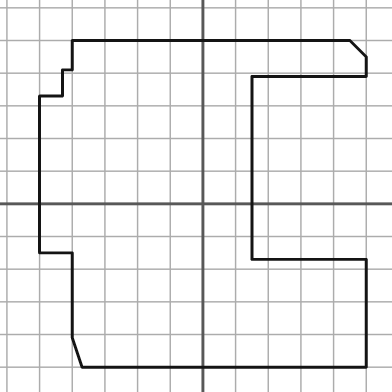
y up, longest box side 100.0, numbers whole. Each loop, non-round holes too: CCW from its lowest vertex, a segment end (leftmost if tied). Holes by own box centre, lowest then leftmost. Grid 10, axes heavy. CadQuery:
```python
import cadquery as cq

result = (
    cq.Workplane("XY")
    .moveTo(-37.0, -50.0)
    .lineTo(50.0, -50.0)
    .lineTo(50.0, -17.0)
    .lineTo(15.0, -17.0)
    .lineTo(15.0, 39.0)
    .lineTo(50.0, 39.0)
    .lineTo(50.0, 45.0)
    .lineTo(45.0, 50.0)
    .lineTo(-40.0, 50.0)
    .lineTo(-40.0, 41.0)
    .lineTo(-43.0, 41.0)
    .lineTo(-43.0, 33.0)
    .lineTo(-50.0, 33.0)
    .lineTo(-50.0, -15.0)
    .lineTo(-40.0, -15.0)
    .lineTo(-40.0, -41.0)
    .close()
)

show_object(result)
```